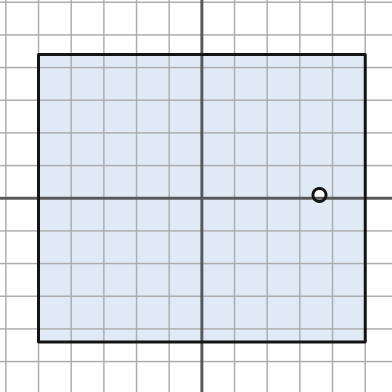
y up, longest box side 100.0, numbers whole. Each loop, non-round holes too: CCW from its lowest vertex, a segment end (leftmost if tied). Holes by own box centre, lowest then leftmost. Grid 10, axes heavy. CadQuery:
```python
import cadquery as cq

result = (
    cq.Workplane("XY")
    .moveTo(-50.0, -44.0)
    .lineTo(50.0, -44.0)
    .lineTo(50.0, 44.0)
    .lineTo(-50.0, 44.0)
    .close()
    .moveTo(36.0, 1.0)
    .circle(2.0)
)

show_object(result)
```